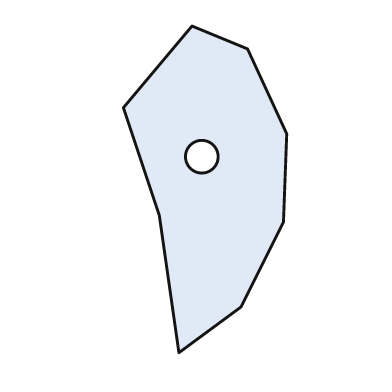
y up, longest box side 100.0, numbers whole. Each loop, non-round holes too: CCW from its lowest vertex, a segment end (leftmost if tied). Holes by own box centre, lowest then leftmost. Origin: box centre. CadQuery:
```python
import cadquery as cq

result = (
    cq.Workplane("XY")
    .moveTo(-8.0, -50.0)
    .lineTo(11.0, -36.0)
    .lineTo(24.0, -10.0)
    .lineTo(25.0, 17.0)
    .lineTo(13.0, 43.0)
    .lineTo(-4.0, 50.0)
    .lineTo(-25.0, 25.0)
    .lineTo(-14.0, -8.0)
    .close()
    .moveTo(-1.0, 10.0)
    .circle(5.0)
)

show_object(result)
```